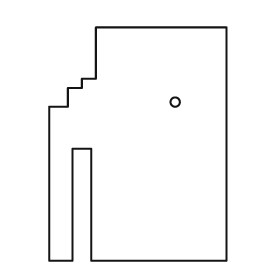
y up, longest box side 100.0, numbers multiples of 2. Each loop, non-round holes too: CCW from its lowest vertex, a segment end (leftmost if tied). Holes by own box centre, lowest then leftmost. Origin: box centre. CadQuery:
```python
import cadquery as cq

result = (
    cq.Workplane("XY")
    .moveTo(-38.0, -50.0)
    .lineTo(-28.0, -50.0)
    .lineTo(-28.0, -2.0)
    .lineTo(-20.0, -2.0)
    .lineTo(-20.0, -50.0)
    .lineTo(38.0, -50.0)
    .lineTo(38.0, 50.0)
    .lineTo(-18.0, 50.0)
    .lineTo(-18.0, 28.0)
    .lineTo(-24.0, 28.0)
    .lineTo(-24.0, 24.0)
    .lineTo(-30.0, 24.0)
    .lineTo(-30.0, 16.0)
    .lineTo(-38.0, 16.0)
    .close()
    .moveTo(16.0, 18.0)
    .circle(2.0)
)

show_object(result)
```